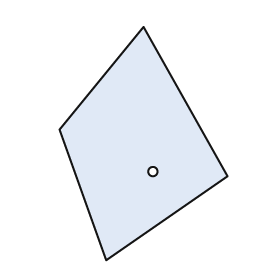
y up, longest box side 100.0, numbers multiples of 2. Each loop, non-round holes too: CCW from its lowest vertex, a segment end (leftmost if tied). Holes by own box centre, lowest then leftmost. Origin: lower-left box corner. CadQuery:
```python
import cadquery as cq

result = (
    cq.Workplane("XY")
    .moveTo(20.0, 0.0)
    .lineTo(72.0, 36.0)
    .lineTo(36.0, 100.0)
    .lineTo(0.0, 56.0)
    .close()
    .moveTo(40.0, 38.0)
    .circle(2.0)
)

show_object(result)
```